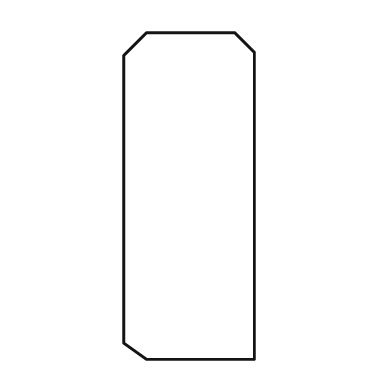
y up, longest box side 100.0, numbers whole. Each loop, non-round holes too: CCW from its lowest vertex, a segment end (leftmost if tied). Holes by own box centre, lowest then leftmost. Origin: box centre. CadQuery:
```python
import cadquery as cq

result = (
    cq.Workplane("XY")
    .moveTo(-13.0, -50.0)
    .lineTo(20.0, -50.0)
    .lineTo(20.0, 44.0)
    .lineTo(14.0, 50.0)
    .lineTo(-13.0, 50.0)
    .lineTo(-20.0, 43.0)
    .lineTo(-20.0, -45.0)
    .close()
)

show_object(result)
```